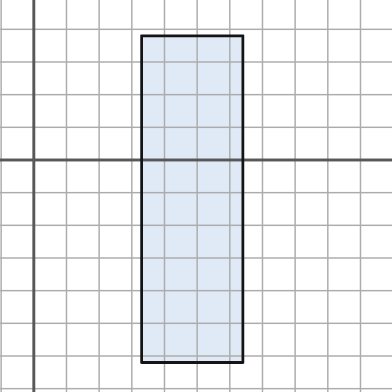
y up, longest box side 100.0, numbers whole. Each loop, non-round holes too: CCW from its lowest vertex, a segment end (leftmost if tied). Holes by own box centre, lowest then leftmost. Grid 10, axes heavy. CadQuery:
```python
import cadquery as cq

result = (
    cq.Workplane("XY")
    .moveTo(33.0, -62.0)
    .lineTo(64.0, -62.0)
    .lineTo(64.0, 38.0)
    .lineTo(33.0, 38.0)
    .close()
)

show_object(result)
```